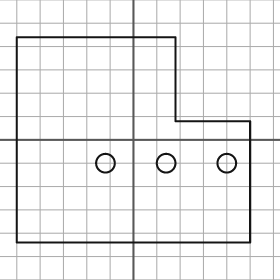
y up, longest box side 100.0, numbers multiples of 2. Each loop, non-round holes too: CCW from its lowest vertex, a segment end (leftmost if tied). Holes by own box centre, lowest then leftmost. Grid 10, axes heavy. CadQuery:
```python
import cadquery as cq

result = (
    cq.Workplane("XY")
    .moveTo(-50.0, -44.0)
    .lineTo(50.0, -44.0)
    .lineTo(50.0, 8.0)
    .lineTo(18.0, 8.0)
    .lineTo(18.0, 44.0)
    .lineTo(-50.0, 44.0)
    .close()
    .moveTo(-12.0, -10.0)
    .circle(4.0)
    .moveTo(14.0, -10.0)
    .circle(4.0)
    .moveTo(40.0, -10.0)
    .circle(4.0)
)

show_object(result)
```